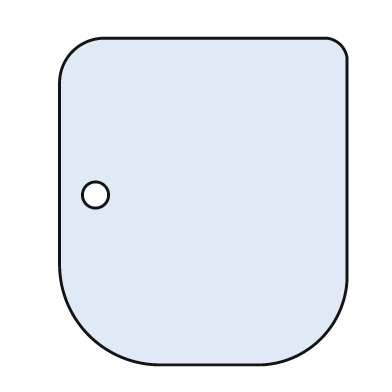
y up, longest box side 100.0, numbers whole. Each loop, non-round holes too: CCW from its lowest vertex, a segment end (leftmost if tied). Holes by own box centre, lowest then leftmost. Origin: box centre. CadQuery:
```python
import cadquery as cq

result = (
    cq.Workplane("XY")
    .moveTo(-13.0, -50.0)
    .lineTo(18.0, -50.0)
    .threePointArc((36.0, -42.0), (44.0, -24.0))
    .lineTo(44.0, 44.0)
    .threePointArc((42.0, 48.0), (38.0, 50.0))
    .lineTo(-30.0, 50.0)
    .threePointArc((-40.0, 46.0), (-44.0, 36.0))
    .lineTo(-44.0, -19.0)
    .threePointArc((-35.0, -41.0), (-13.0, -50.0))
    .close()
    .moveTo(-33.0, 2.0)
    .circle(4.0)
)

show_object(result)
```